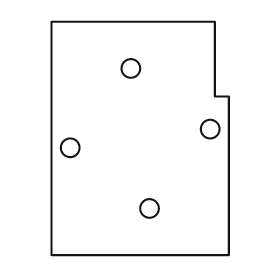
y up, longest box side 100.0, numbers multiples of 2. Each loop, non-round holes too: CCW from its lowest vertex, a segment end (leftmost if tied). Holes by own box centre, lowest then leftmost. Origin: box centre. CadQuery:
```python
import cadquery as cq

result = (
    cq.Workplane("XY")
    .moveTo(-38.0, -50.0)
    .lineTo(38.0, -50.0)
    .lineTo(38.0, 18.0)
    .lineTo(32.0, 18.0)
    .lineTo(32.0, 50.0)
    .lineTo(-38.0, 50.0)
    .close()
    .moveTo(4.0, -30.0)
    .circle(4.0)
    .moveTo(-30.0, -4.0)
    .circle(4.0)
    .moveTo(30.0, 4.0)
    .circle(4.0)
    .moveTo(-4.0, 30.0)
    .circle(4.0)
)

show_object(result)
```